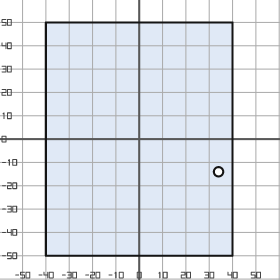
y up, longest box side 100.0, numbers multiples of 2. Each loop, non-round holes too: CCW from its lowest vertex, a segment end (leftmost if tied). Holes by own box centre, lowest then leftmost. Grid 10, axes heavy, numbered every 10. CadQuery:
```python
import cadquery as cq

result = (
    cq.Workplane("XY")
    .moveTo(-40.0, -50.0)
    .lineTo(40.0, -50.0)
    .lineTo(40.0, 50.0)
    .lineTo(-40.0, 50.0)
    .close()
    .moveTo(34.0, -14.0)
    .circle(2.0)
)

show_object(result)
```